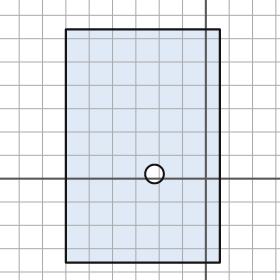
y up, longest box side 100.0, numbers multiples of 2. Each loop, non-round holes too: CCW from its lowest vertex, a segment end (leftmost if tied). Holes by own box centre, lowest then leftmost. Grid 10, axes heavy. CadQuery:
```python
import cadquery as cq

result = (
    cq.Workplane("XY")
    .moveTo(-60.0, -36.0)
    .lineTo(6.0, -36.0)
    .lineTo(6.0, 64.0)
    .lineTo(-60.0, 64.0)
    .close()
    .moveTo(-22.0, 2.0)
    .circle(4.0)
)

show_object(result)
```